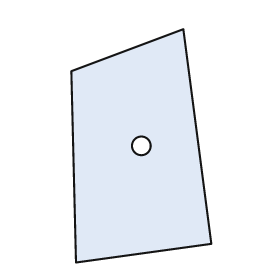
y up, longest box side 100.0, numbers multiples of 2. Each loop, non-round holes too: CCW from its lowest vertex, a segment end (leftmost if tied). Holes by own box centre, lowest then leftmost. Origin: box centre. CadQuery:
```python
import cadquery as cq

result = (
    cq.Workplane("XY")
    .moveTo(-28.0, -50.0)
    .lineTo(30.0, -42.0)
    .lineTo(18.0, 50.0)
    .lineTo(-30.0, 32.0)
    .close()
    .moveTo(0.0, 0.0)
    .circle(4.0)
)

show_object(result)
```